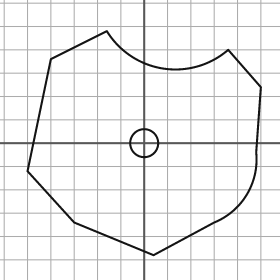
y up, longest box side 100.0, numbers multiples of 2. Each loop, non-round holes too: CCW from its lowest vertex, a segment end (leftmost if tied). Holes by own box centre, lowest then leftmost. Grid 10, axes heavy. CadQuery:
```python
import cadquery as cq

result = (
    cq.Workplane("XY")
    .moveTo(4.0, -48.0)
    .lineTo(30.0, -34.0)
    .threePointArc((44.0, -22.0), (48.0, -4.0))
    .lineTo(50.0, 24.0)
    .lineTo(36.0, 40.0)
    .threePointArc((8.0, 32.0), (-16.0, 48.0))
    .lineTo(-40.0, 36.0)
    .lineTo(-50.0, -12.0)
    .lineTo(-30.0, -34.0)
    .close()
    .moveTo(0.0, 0.0)
    .circle(6.0)
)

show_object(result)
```